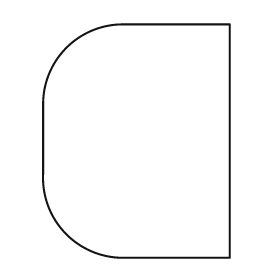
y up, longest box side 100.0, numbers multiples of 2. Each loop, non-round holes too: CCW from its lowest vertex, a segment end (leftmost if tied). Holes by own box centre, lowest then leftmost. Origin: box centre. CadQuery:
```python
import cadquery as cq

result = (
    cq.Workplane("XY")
    .moveTo(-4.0, -50.0)
    .lineTo(40.0, -50.0)
    .lineTo(40.0, 50.0)
    .lineTo(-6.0, 50.0)
    .threePointArc((-30.0, 40.0), (-40.0, 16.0))
    .lineTo(-40.0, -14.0)
    .threePointArc((-30.0, -40.0), (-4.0, -50.0))
    .close()
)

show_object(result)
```